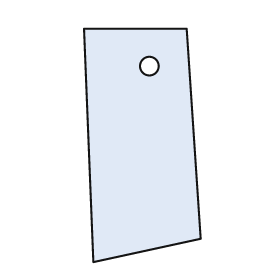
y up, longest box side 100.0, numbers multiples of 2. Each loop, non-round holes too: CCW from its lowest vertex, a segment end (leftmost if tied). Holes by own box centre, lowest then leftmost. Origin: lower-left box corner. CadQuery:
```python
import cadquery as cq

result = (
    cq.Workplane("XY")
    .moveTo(4.0, 0.0)
    .lineTo(50.0, 10.0)
    .lineTo(44.0, 100.0)
    .lineTo(0.0, 100.0)
    .close()
    .moveTo(28.0, 84.0)
    .circle(4.0)
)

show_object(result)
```